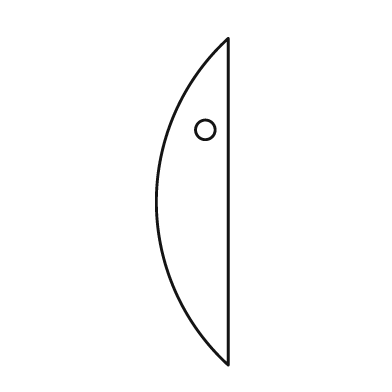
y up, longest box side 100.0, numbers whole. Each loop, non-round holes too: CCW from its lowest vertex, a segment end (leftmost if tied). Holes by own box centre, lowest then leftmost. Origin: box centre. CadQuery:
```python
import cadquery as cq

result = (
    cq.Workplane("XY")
    .moveTo(11.0, -50.0)
    .lineTo(11.0, 50.0)
    .threePointArc((-11.0, 0.0), (11.0, -50.0))
    .close()
    .moveTo(4.0, 22.0)
    .circle(3.0)
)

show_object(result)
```